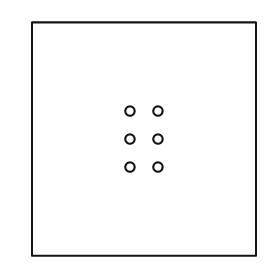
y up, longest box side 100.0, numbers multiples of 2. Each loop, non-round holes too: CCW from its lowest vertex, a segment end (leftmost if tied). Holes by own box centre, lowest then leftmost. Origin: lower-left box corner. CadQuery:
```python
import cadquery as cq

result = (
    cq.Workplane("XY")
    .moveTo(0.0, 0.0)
    .lineTo(96.0, 0.0)
    .lineTo(96.0, 100.0)
    .lineTo(0.0, 100.0)
    .close()
    .moveTo(42.0, 38.0)
    .circle(2.0)
    .moveTo(54.0, 38.0)
    .circle(2.0)
    .moveTo(42.0, 50.0)
    .circle(2.0)
    .moveTo(54.0, 50.0)
    .circle(2.0)
    .moveTo(42.0, 62.0)
    .circle(2.0)
    .moveTo(54.0, 62.0)
    .circle(2.0)
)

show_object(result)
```